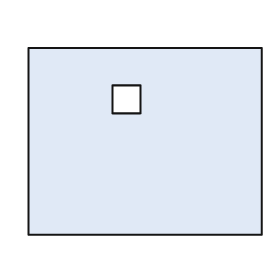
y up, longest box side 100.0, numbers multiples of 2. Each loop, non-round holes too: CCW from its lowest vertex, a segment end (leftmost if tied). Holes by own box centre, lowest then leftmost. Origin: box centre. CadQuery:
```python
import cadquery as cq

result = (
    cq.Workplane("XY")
    .moveTo(-50.0, -40.0)
    .lineTo(50.0, -40.0)
    .lineTo(50.0, 40.0)
    .lineTo(-50.0, 40.0)
    .close()
    .moveTo(-14.0, 12.0)
    .lineTo(-2.0, 12.0)
    .lineTo(-2.0, 24.0)
    .lineTo(-14.0, 24.0)
    .close()
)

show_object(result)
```